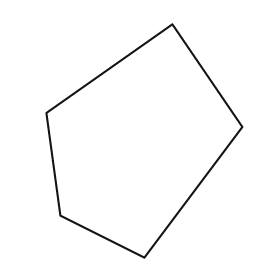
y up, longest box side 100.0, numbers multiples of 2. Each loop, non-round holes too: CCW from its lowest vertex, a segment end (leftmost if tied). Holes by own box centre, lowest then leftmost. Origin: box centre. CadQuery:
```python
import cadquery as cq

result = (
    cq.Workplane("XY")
    .moveTo(0.0, -50.0)
    .lineTo(42.0, 6.0)
    .lineTo(12.0, 50.0)
    .lineTo(-42.0, 12.0)
    .lineTo(-36.0, -32.0)
    .close()
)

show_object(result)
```